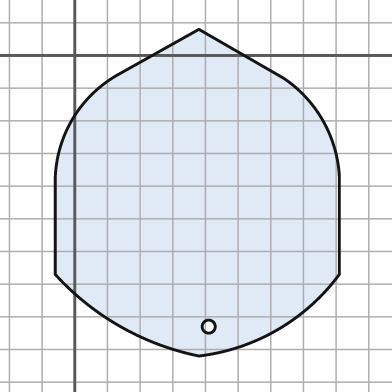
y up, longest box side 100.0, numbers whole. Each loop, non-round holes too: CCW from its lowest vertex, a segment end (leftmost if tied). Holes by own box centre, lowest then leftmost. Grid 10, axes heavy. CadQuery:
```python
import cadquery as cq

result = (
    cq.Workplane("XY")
    .moveTo(38.0, -92.0)
    .threePointArc((62.0, -84.0), (81.0, -67.0))
    .lineTo(81.0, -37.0)
    .threePointArc((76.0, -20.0), (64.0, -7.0))
    .lineTo(38.0, 8.0)
    .lineTo(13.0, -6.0)
    .threePointArc((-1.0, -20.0), (-6.0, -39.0))
    .lineTo(-6.0, -67.0)
    .threePointArc((14.0, -83.0), (38.0, -92.0))
    .close()
    .moveTo(41.0, -83.0)
    .circle(2.0)
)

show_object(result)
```